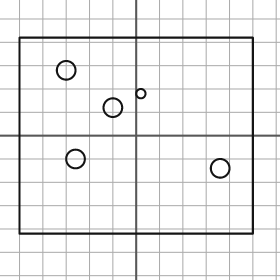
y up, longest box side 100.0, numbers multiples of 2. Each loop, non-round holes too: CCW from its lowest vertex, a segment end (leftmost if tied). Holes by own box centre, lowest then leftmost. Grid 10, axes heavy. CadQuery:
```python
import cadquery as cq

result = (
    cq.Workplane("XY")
    .moveTo(-50.0, -42.0)
    .lineTo(50.0, -42.0)
    .lineTo(50.0, 42.0)
    .lineTo(-50.0, 42.0)
    .close()
    .moveTo(36.0, -14.0)
    .circle(4.0)
    .moveTo(-26.0, -10.0)
    .circle(4.0)
    .moveTo(-10.0, 12.0)
    .circle(4.0)
    .moveTo(2.0, 18.0)
    .circle(2.0)
    .moveTo(-30.0, 28.0)
    .circle(4.0)
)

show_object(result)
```